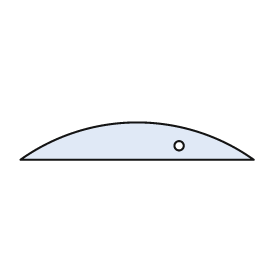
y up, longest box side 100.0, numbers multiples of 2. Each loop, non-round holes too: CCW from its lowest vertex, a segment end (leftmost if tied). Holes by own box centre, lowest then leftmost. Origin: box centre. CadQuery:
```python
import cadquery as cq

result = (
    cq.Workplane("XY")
    .moveTo(-50.0, -8.0)
    .lineTo(50.0, -8.0)
    .threePointArc((0.0, 8.0), (-50.0, -8.0))
    .close()
    .moveTo(18.0, -2.0)
    .circle(2.0)
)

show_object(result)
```